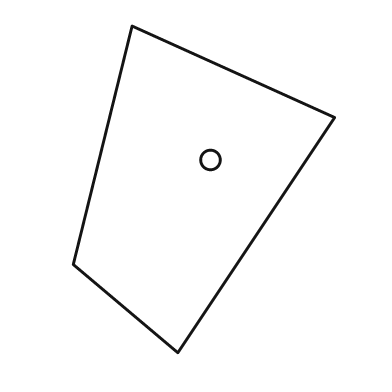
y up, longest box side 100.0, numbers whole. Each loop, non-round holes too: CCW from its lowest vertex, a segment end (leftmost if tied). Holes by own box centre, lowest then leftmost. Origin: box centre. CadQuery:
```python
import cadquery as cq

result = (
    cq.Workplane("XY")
    .moveTo(-8.0, -50.0)
    .lineTo(40.0, 22.0)
    .lineTo(-22.0, 50.0)
    .lineTo(-40.0, -23.0)
    .close()
    .moveTo(2.0, 9.0)
    .circle(3.0)
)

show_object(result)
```